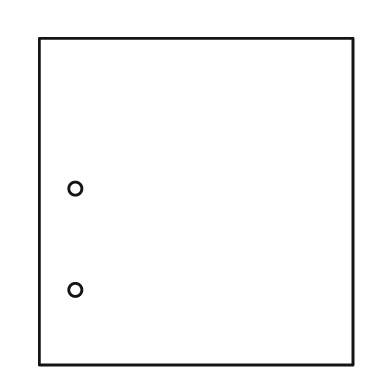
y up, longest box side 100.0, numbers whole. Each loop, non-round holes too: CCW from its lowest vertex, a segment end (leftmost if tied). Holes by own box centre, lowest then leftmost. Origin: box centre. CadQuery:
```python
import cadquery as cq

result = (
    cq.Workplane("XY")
    .moveTo(-48.0, -50.0)
    .lineTo(48.0, -50.0)
    .lineTo(48.0, 50.0)
    .lineTo(-48.0, 50.0)
    .close()
    .moveTo(-37.0, -27.0)
    .circle(2.0)
    .moveTo(-37.0, 4.0)
    .circle(2.0)
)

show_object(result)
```